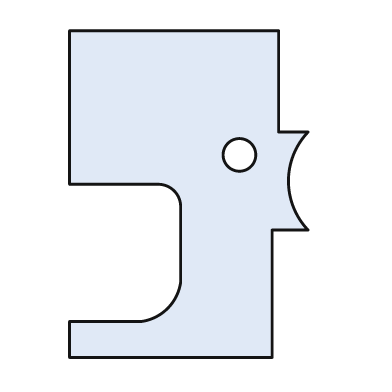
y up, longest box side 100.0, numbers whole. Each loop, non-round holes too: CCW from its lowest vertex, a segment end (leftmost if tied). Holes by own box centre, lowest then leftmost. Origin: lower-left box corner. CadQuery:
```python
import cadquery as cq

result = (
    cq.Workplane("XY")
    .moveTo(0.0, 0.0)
    .lineTo(62.0, 0.0)
    .lineTo(62.0, 39.0)
    .lineTo(73.0, 39.0)
    .threePointArc((67.0, 54.0), (73.0, 69.0))
    .lineTo(64.0, 69.0)
    .lineTo(64.0, 100.0)
    .lineTo(0.0, 100.0)
    .lineTo(0.0, 53.0)
    .lineTo(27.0, 53.0)
    .threePointArc((32.0, 51.0), (34.0, 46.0))
    .lineTo(34.0, 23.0)
    .threePointArc((30.0, 15.0), (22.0, 11.0))
    .lineTo(0.0, 11.0)
    .close()
    .moveTo(52.0, 62.0)
    .circle(5.0)
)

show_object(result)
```